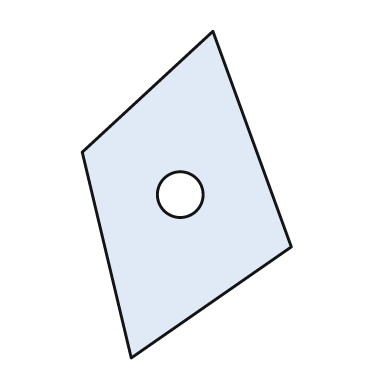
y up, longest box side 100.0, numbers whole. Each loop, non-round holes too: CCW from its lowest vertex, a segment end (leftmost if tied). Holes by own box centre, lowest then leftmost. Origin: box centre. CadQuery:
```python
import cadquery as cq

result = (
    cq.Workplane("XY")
    .moveTo(-17.0, -50.0)
    .lineTo(32.0, -16.0)
    .lineTo(8.0, 50.0)
    .lineTo(-32.0, 13.0)
    .close()
    .moveTo(-2.0, 0.0)
    .circle(7.0)
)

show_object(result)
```